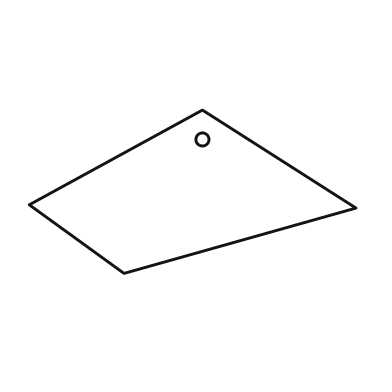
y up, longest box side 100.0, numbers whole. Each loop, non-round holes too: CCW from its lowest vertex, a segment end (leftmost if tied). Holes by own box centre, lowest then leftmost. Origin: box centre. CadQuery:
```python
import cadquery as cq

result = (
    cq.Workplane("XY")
    .moveTo(-21.0, -25.0)
    .lineTo(50.0, -5.0)
    .lineTo(3.0, 25.0)
    .lineTo(-50.0, -4.0)
    .close()
    .moveTo(3.0, 16.0)
    .circle(2.0)
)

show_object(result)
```